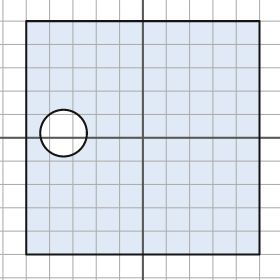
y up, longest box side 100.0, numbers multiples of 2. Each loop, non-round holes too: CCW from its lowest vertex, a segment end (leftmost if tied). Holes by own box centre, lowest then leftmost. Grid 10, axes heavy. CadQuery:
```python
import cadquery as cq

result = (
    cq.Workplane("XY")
    .moveTo(-50.0, -50.0)
    .lineTo(50.0, -50.0)
    .lineTo(50.0, 50.0)
    .lineTo(-50.0, 50.0)
    .close()
    .moveTo(-34.0, 2.0)
    .circle(10.0)
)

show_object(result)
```